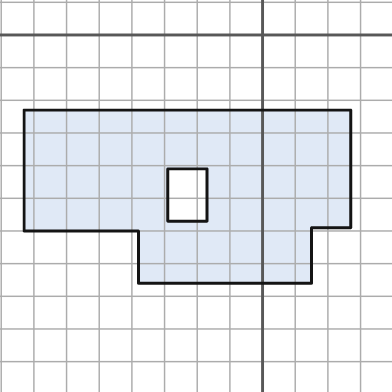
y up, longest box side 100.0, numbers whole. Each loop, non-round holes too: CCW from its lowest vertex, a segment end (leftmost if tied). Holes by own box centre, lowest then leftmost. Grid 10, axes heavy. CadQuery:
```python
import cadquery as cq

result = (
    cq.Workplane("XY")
    .moveTo(-38.0, -76.0)
    .lineTo(15.0, -76.0)
    .lineTo(15.0, -59.0)
    .lineTo(27.0, -59.0)
    .lineTo(27.0, -23.0)
    .lineTo(-73.0, -23.0)
    .lineTo(-73.0, -60.0)
    .lineTo(-38.0, -60.0)
    .close()
    .moveTo(-29.0, -57.0)
    .lineTo(-17.0, -57.0)
    .lineTo(-17.0, -41.0)
    .lineTo(-29.0, -41.0)
    .close()
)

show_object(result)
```